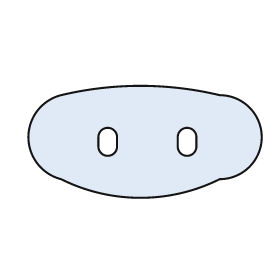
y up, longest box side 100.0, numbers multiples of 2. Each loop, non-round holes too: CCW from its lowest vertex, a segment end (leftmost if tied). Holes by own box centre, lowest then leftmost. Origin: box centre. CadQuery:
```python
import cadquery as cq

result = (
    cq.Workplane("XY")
    .moveTo(-36.0, -16.0)
    .threePointArc((-2.0, -24.0), (32.0, -16.0))
    .threePointArc((50.0, 2.0), (32.0, 20.0))
    .threePointArc((-2.0, 24.0), (-36.0, 20.0))
    .threePointArc((-50.0, 2.0), (-36.0, -16.0))
    .close()
    .moveTo(-20.0, -2.0)
    .threePointArc((-16.0, -6.0), (-12.0, -2.0))
    .lineTo(-12.0, 2.0)
    .threePointArc((-16.0, 6.0), (-20.0, 2.0))
    .close()
    .moveTo(14.0, -2.0)
    .threePointArc((18.0, -6.0), (22.0, -2.0))
    .lineTo(22.0, 2.0)
    .threePointArc((18.0, 6.0), (14.0, 2.0))
    .close()
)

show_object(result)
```